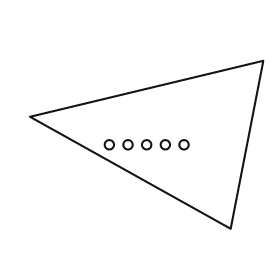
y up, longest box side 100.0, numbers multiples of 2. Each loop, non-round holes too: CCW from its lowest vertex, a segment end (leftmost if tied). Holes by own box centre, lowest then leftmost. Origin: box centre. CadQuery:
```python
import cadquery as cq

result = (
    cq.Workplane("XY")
    .moveTo(36.0, -36.0)
    .lineTo(50.0, 36.0)
    .lineTo(-50.0, 12.0)
    .close()
    .moveTo(-16.0, 0.0)
    .circle(2.0)
    .moveTo(-8.0, 0.0)
    .circle(2.0)
    .moveTo(0.0, 0.0)
    .circle(2.0)
    .moveTo(8.0, 0.0)
    .circle(2.0)
    .moveTo(16.0, 0.0)
    .circle(2.0)
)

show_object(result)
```